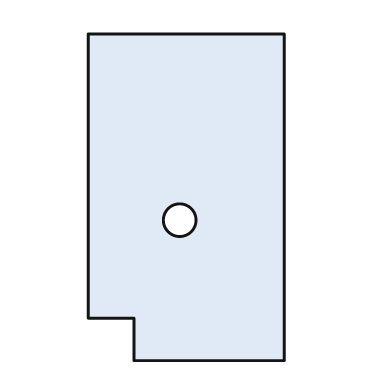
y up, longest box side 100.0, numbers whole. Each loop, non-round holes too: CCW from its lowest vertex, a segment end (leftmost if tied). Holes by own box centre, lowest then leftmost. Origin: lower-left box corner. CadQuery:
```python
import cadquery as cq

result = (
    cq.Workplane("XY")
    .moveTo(14.0, 0.0)
    .lineTo(60.0, 0.0)
    .lineTo(60.0, 100.0)
    .lineTo(0.0, 100.0)
    .lineTo(0.0, 13.0)
    .lineTo(14.0, 13.0)
    .close()
    .moveTo(28.0, 43.0)
    .circle(5.0)
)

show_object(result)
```